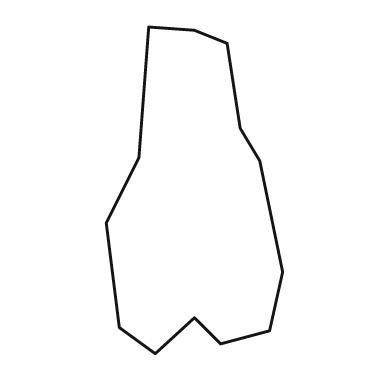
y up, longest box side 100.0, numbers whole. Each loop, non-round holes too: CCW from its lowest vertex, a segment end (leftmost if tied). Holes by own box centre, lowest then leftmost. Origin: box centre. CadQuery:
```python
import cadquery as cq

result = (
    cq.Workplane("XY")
    .moveTo(-12.0, -50.0)
    .lineTo(0.0, -39.0)
    .lineTo(8.0, -47.0)
    .lineTo(23.0, -43.0)
    .lineTo(27.0, -25.0)
    .lineTo(20.0, 9.0)
    .lineTo(14.0, 19.0)
    .lineTo(10.0, 45.0)
    .lineTo(0.0, 49.0)
    .lineTo(-14.0, 50.0)
    .lineTo(-17.0, 10.0)
    .lineTo(-27.0, -10.0)
    .lineTo(-23.0, -42.0)
    .close()
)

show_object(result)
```